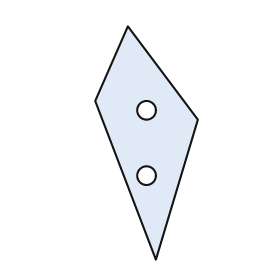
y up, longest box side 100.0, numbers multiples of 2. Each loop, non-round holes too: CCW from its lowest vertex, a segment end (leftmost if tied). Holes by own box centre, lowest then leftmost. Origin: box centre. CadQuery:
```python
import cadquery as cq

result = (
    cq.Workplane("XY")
    .moveTo(4.0, -50.0)
    .lineTo(22.0, 10.0)
    .lineTo(-8.0, 50.0)
    .lineTo(-22.0, 18.0)
    .close()
    .moveTo(0.0, -14.0)
    .circle(4.0)
    .moveTo(0.0, 14.0)
    .circle(4.0)
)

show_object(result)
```